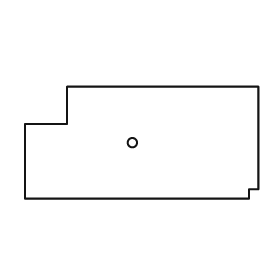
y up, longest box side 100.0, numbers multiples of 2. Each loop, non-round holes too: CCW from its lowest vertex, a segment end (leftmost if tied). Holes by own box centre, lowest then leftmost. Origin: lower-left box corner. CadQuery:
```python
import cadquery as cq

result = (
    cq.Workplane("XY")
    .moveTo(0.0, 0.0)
    .lineTo(96.0, 0.0)
    .lineTo(96.0, 4.0)
    .lineTo(100.0, 4.0)
    .lineTo(100.0, 48.0)
    .lineTo(18.0, 48.0)
    .lineTo(18.0, 32.0)
    .lineTo(0.0, 32.0)
    .close()
    .moveTo(46.0, 24.0)
    .circle(2.0)
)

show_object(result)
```